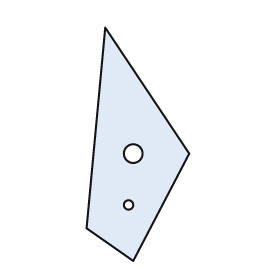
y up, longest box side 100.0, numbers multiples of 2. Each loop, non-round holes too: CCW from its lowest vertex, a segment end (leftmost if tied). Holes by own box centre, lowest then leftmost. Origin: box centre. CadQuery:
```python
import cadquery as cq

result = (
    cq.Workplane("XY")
    .moveTo(-2.0, -50.0)
    .lineTo(22.0, -4.0)
    .lineTo(-14.0, 50.0)
    .lineTo(-22.0, -36.0)
    .close()
    .moveTo(-4.0, -26.0)
    .circle(2.0)
    .moveTo(-2.0, -4.0)
    .circle(4.0)
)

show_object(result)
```